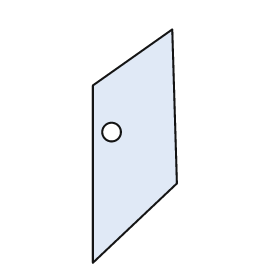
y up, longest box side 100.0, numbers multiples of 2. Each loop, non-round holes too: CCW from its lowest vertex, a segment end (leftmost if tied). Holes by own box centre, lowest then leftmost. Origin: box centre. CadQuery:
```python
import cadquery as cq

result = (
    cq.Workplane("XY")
    .moveTo(-18.0, -50.0)
    .lineTo(18.0, -16.0)
    .lineTo(16.0, 50.0)
    .lineTo(-18.0, 26.0)
    .close()
    .moveTo(-10.0, 6.0)
    .circle(4.0)
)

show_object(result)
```